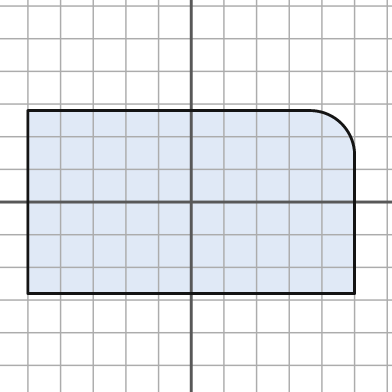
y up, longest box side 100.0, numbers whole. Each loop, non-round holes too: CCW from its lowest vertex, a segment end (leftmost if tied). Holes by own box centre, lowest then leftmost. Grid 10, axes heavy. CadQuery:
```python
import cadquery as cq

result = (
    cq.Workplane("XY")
    .moveTo(-50.0, -28.0)
    .lineTo(50.0, -28.0)
    .lineTo(50.0, 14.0)
    .threePointArc((46.0, 24.0), (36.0, 28.0))
    .lineTo(-50.0, 28.0)
    .close()
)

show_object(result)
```